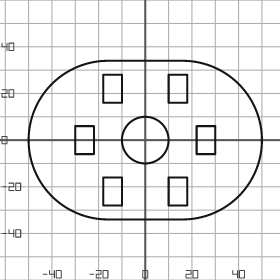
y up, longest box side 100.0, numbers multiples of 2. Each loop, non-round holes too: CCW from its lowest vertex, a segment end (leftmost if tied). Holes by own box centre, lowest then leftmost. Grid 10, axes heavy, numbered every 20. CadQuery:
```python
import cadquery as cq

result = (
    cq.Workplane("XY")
    .moveTo(-16.0, -34.0)
    .lineTo(16.0, -34.0)
    .threePointArc((50.0, 0.0), (16.0, 34.0))
    .lineTo(-16.0, 34.0)
    .threePointArc((-50.0, 0.0), (-16.0, -34.0))
    .close()
    .moveTo(-18.0, -28.0)
    .lineTo(-10.0, -28.0)
    .lineTo(-10.0, -16.0)
    .lineTo(-18.0, -16.0)
    .close()
    .moveTo(10.0, -28.0)
    .lineTo(18.0, -28.0)
    .lineTo(18.0, -16.0)
    .lineTo(10.0, -16.0)
    .close()
    .moveTo(-30.0, -6.0)
    .lineTo(-22.0, -6.0)
    .lineTo(-22.0, 6.0)
    .lineTo(-30.0, 6.0)
    .close()
    .moveTo(0.0, 0.0)
    .circle(10.0)
    .moveTo(22.0, -6.0)
    .lineTo(30.0, -6.0)
    .lineTo(30.0, 6.0)
    .lineTo(22.0, 6.0)
    .close()
    .moveTo(-18.0, 16.0)
    .lineTo(-10.0, 16.0)
    .lineTo(-10.0, 28.0)
    .lineTo(-18.0, 28.0)
    .close()
    .moveTo(10.0, 16.0)
    .lineTo(18.0, 16.0)
    .lineTo(18.0, 28.0)
    .lineTo(10.0, 28.0)
    .close()
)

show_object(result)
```